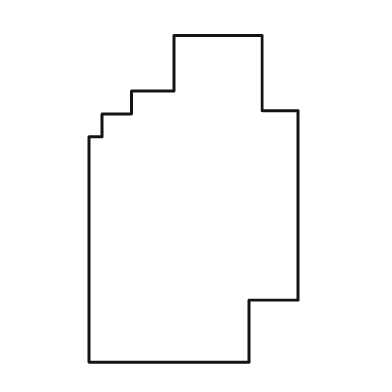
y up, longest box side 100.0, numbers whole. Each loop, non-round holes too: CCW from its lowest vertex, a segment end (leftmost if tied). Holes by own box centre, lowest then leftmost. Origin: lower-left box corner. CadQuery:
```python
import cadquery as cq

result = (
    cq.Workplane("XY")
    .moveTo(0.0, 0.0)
    .lineTo(49.0, 0.0)
    .lineTo(49.0, 19.0)
    .lineTo(64.0, 19.0)
    .lineTo(64.0, 77.0)
    .lineTo(53.0, 77.0)
    .lineTo(53.0, 100.0)
    .lineTo(26.0, 100.0)
    .lineTo(26.0, 83.0)
    .lineTo(13.0, 83.0)
    .lineTo(13.0, 76.0)
    .lineTo(4.0, 76.0)
    .lineTo(4.0, 69.0)
    .lineTo(0.0, 69.0)
    .close()
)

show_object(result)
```